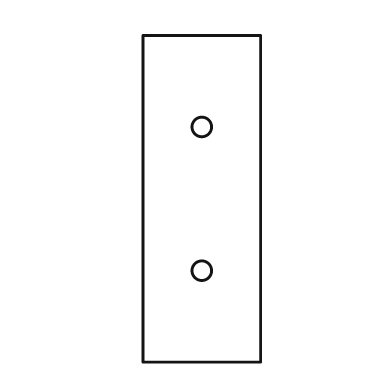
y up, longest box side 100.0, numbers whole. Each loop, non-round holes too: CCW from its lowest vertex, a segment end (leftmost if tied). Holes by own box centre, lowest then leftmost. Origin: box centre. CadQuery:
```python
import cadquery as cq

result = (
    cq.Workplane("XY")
    .moveTo(-18.0, -50.0)
    .lineTo(18.0, -50.0)
    .lineTo(18.0, 50.0)
    .lineTo(-18.0, 50.0)
    .close()
    .moveTo(0.0, -22.0)
    .circle(3.0)
    .moveTo(0.0, 22.0)
    .circle(3.0)
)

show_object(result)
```